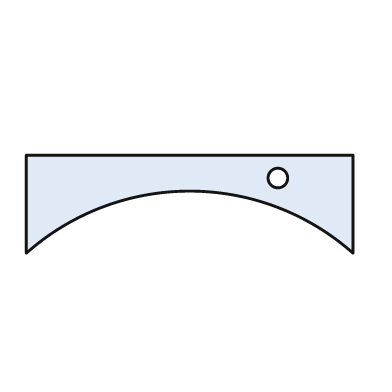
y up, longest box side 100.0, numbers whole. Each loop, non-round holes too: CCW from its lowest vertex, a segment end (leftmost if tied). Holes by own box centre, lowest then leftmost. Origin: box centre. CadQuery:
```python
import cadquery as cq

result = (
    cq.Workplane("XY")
    .moveTo(-50.0, -15.0)
    .threePointArc((0.0, 4.0), (50.0, -15.0))
    .lineTo(50.0, 15.0)
    .lineTo(-50.0, 15.0)
    .close()
    .moveTo(27.0, 8.0)
    .circle(3.0)
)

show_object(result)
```